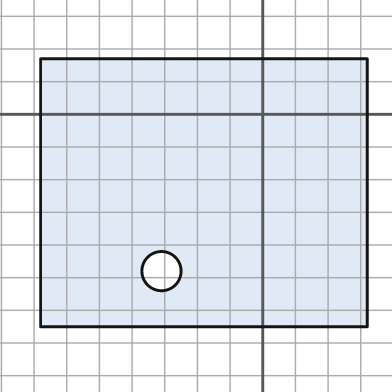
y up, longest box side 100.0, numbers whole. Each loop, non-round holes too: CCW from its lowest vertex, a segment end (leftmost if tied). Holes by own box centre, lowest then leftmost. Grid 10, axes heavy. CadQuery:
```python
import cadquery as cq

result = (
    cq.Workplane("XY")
    .moveTo(-68.0, -65.0)
    .lineTo(32.0, -65.0)
    .lineTo(32.0, 17.0)
    .lineTo(-68.0, 17.0)
    .close()
    .moveTo(-31.0, -48.0)
    .circle(6.0)
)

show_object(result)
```